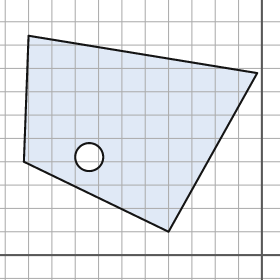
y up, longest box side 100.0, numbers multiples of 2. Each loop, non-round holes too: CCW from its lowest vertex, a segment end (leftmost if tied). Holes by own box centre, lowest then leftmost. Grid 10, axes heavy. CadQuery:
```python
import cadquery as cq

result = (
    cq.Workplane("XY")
    .moveTo(-40.0, 10.0)
    .lineTo(-2.0, 78.0)
    .lineTo(-100.0, 94.0)
    .lineTo(-102.0, 40.0)
    .close()
    .moveTo(-74.0, 42.0)
    .circle(6.0)
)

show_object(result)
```